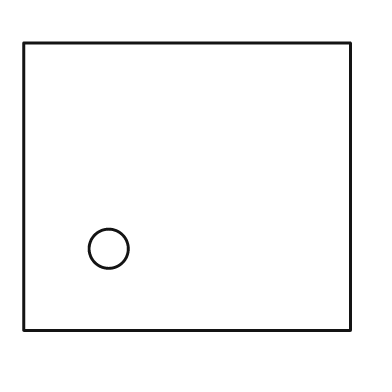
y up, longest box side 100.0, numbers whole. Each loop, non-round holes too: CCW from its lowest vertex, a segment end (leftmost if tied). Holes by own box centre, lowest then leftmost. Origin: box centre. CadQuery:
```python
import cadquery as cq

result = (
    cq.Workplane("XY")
    .moveTo(-50.0, -44.0)
    .lineTo(50.0, -44.0)
    .lineTo(50.0, 44.0)
    .lineTo(-50.0, 44.0)
    .close()
    .moveTo(-24.0, -19.0)
    .circle(6.0)
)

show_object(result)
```